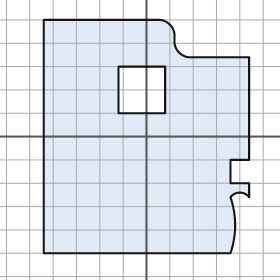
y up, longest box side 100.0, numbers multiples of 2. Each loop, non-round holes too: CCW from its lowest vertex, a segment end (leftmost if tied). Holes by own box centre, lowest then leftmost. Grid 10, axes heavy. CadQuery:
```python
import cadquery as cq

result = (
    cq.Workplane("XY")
    .moveTo(-44.0, -50.0)
    .lineTo(36.0, -50.0)
    .threePointArc((38.0, -38.0), (36.0, -26.0))
    .threePointArc((40.0, -24.0), (44.0, -26.0))
    .lineTo(44.0, -20.0)
    .lineTo(36.0, -20.0)
    .lineTo(36.0, -10.0)
    .lineTo(44.0, -10.0)
    .lineTo(44.0, 34.0)
    .lineTo(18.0, 34.0)
    .threePointArc((14.0, 36.0), (12.0, 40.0))
    .lineTo(12.0, 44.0)
    .threePointArc((10.0, 48.0), (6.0, 50.0))
    .lineTo(-44.0, 50.0)
    .close()
    .moveTo(-12.0, 10.0)
    .lineTo(8.0, 10.0)
    .lineTo(8.0, 30.0)
    .lineTo(-12.0, 30.0)
    .close()
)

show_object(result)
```